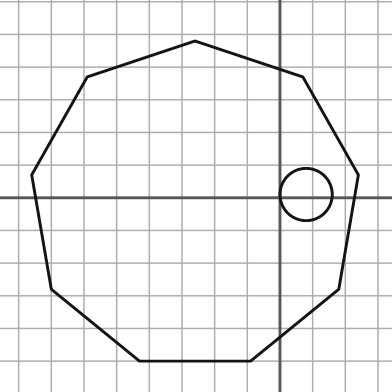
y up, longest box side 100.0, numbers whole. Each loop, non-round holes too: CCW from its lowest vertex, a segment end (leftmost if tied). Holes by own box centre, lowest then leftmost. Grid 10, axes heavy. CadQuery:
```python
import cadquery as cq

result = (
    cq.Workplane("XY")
    .moveTo(-43.0, -50.0)
    .lineTo(-9.0, -50.0)
    .lineTo(18.0, -28.0)
    .lineTo(24.0, 7.0)
    .lineTo(7.0, 37.0)
    .lineTo(-26.0, 48.0)
    .lineTo(-59.0, 37.0)
    .lineTo(-76.0, 7.0)
    .lineTo(-70.0, -28.0)
    .close()
    .moveTo(8.0, 1.0)
    .circle(8.0)
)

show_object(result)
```